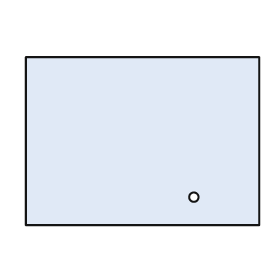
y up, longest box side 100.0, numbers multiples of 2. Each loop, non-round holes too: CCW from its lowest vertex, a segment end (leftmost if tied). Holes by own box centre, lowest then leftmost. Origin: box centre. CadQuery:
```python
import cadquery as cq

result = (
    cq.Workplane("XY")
    .moveTo(-50.0, -36.0)
    .lineTo(50.0, -36.0)
    .lineTo(50.0, 36.0)
    .lineTo(-50.0, 36.0)
    .close()
    .moveTo(22.0, -24.0)
    .circle(2.0)
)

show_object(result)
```